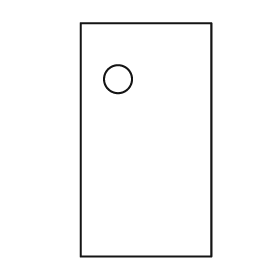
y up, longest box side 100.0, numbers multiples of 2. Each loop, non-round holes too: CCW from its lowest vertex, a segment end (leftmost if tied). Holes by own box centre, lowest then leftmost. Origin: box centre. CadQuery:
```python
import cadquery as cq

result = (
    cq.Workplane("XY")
    .moveTo(-28.0, -50.0)
    .lineTo(28.0, -50.0)
    .lineTo(28.0, 50.0)
    .lineTo(-28.0, 50.0)
    .close()
    .moveTo(-12.0, 26.0)
    .circle(6.0)
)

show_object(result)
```